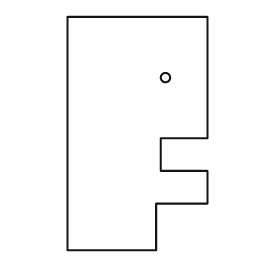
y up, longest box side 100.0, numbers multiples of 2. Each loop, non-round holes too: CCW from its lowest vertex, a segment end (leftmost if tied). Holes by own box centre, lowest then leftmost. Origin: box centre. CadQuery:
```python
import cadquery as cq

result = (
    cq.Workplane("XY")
    .moveTo(-30.0, -50.0)
    .lineTo(8.0, -50.0)
    .lineTo(8.0, -30.0)
    .lineTo(30.0, -30.0)
    .lineTo(30.0, -16.0)
    .lineTo(10.0, -16.0)
    .lineTo(10.0, -2.0)
    .lineTo(30.0, -2.0)
    .lineTo(30.0, 50.0)
    .lineTo(-30.0, 50.0)
    .close()
    .moveTo(12.0, 24.0)
    .circle(2.0)
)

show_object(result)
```